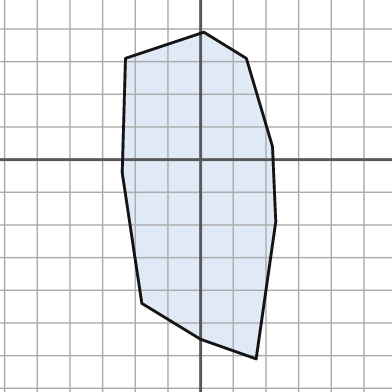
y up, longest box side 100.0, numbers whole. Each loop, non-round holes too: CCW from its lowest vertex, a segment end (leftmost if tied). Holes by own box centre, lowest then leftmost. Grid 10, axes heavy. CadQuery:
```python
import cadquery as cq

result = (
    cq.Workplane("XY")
    .moveTo(17.0, -61.0)
    .lineTo(23.0, -19.0)
    .lineTo(22.0, 4.0)
    .lineTo(14.0, 31.0)
    .lineTo(1.0, 39.0)
    .lineTo(-23.0, 31.0)
    .lineTo(-24.0, -4.0)
    .lineTo(-18.0, -44.0)
    .lineTo(0.0, -55.0)
    .close()
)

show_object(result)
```